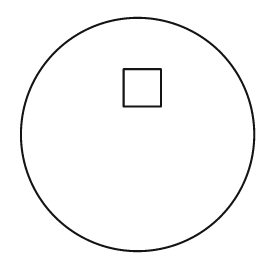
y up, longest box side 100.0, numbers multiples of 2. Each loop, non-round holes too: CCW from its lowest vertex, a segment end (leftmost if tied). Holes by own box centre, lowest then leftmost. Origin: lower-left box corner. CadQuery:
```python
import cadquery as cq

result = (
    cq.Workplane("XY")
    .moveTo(50.0, 50.0)
    .circle(50.0)
    .moveTo(44.0, 62.0)
    .lineTo(60.0, 62.0)
    .lineTo(60.0, 78.0)
    .lineTo(44.0, 78.0)
    .close()
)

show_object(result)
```